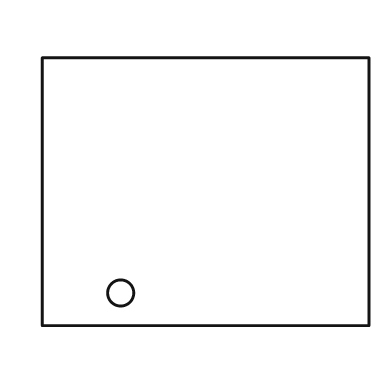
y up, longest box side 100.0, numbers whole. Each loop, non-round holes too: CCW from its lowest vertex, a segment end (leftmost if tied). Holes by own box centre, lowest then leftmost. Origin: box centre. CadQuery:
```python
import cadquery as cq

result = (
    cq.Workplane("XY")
    .moveTo(-50.0, -41.0)
    .lineTo(50.0, -41.0)
    .lineTo(50.0, 41.0)
    .lineTo(-50.0, 41.0)
    .close()
    .moveTo(-26.0, -31.0)
    .circle(4.0)
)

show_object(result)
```